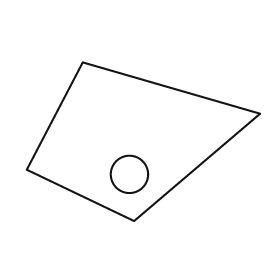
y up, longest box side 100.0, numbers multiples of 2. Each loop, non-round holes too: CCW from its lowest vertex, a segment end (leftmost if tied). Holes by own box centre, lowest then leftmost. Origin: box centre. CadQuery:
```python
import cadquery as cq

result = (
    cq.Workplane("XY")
    .moveTo(-4.0, -34.0)
    .lineTo(50.0, 12.0)
    .lineTo(-26.0, 34.0)
    .lineTo(-50.0, -12.0)
    .close()
    .moveTo(-6.0, -14.0)
    .circle(8.0)
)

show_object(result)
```